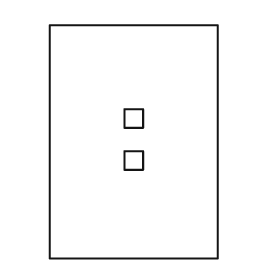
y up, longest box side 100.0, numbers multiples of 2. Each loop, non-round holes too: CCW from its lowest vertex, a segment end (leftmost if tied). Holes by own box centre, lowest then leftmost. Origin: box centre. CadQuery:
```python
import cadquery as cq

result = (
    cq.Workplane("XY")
    .moveTo(-36.0, -50.0)
    .lineTo(36.0, -50.0)
    .lineTo(36.0, 50.0)
    .lineTo(-36.0, 50.0)
    .close()
    .moveTo(-4.0, -12.0)
    .lineTo(4.0, -12.0)
    .lineTo(4.0, -4.0)
    .lineTo(-4.0, -4.0)
    .close()
    .moveTo(-4.0, 6.0)
    .lineTo(4.0, 6.0)
    .lineTo(4.0, 14.0)
    .lineTo(-4.0, 14.0)
    .close()
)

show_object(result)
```